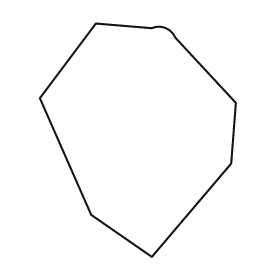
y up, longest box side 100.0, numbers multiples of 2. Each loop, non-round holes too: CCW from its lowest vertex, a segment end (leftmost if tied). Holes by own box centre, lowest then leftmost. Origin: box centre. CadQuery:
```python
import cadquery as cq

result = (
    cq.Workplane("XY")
    .moveTo(6.0, -50.0)
    .lineTo(40.0, -10.0)
    .lineTo(42.0, 16.0)
    .lineTo(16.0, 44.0)
    .threePointArc((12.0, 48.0), (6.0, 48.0))
    .lineTo(-18.0, 50.0)
    .lineTo(-42.0, 18.0)
    .lineTo(-20.0, -32.0)
    .close()
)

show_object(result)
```